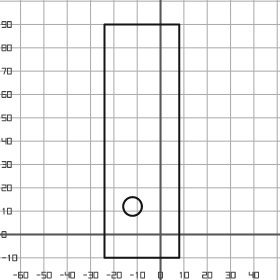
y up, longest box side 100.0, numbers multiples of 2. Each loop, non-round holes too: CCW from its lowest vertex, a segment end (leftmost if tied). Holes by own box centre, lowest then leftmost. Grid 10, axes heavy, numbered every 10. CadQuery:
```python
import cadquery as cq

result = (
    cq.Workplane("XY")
    .moveTo(-24.0, -10.0)
    .lineTo(8.0, -10.0)
    .lineTo(8.0, 90.0)
    .lineTo(-24.0, 90.0)
    .close()
    .moveTo(-12.0, 12.0)
    .circle(4.0)
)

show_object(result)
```